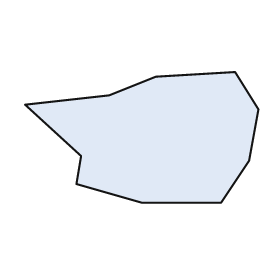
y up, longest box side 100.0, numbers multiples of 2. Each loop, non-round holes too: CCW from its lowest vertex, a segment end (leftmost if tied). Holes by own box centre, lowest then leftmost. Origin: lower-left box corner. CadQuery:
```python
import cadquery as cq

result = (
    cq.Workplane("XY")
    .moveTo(50.0, 0.0)
    .lineTo(84.0, 0.0)
    .lineTo(96.0, 18.0)
    .lineTo(100.0, 40.0)
    .lineTo(90.0, 56.0)
    .lineTo(56.0, 54.0)
    .lineTo(36.0, 46.0)
    .lineTo(0.0, 42.0)
    .lineTo(24.0, 20.0)
    .lineTo(22.0, 8.0)
    .close()
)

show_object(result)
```